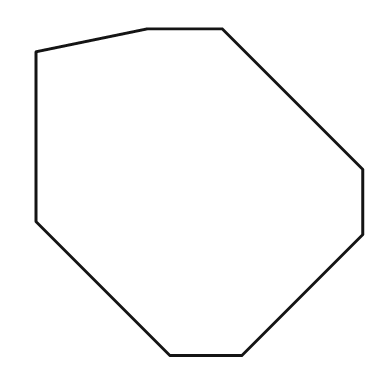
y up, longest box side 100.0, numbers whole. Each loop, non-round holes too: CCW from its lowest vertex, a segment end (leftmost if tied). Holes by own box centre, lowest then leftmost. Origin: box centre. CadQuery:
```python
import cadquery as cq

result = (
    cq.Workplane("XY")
    .moveTo(-9.0, -50.0)
    .lineTo(13.0, -50.0)
    .lineTo(50.0, -13.0)
    .lineTo(50.0, 7.0)
    .lineTo(7.0, 50.0)
    .lineTo(-16.0, 50.0)
    .lineTo(-50.0, 43.0)
    .lineTo(-50.0, -9.0)
    .close()
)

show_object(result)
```